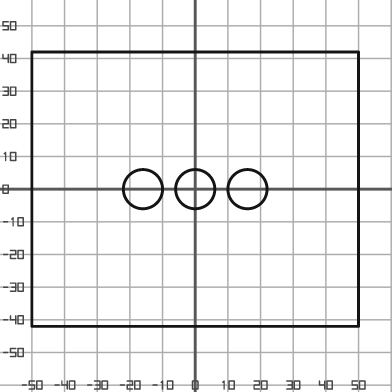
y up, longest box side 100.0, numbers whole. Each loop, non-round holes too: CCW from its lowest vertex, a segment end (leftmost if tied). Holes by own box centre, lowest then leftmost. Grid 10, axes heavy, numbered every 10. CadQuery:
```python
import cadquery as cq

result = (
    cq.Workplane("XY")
    .moveTo(-50.0, -42.0)
    .lineTo(50.0, -42.0)
    .lineTo(50.0, 42.0)
    .lineTo(-50.0, 42.0)
    .close()
    .moveTo(-16.0, 0.0)
    .circle(6.0)
    .moveTo(0.0, 0.0)
    .circle(6.0)
    .moveTo(16.0, 0.0)
    .circle(6.0)
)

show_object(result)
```